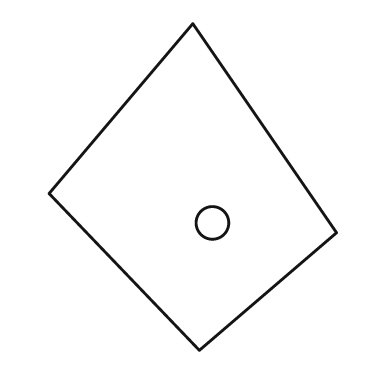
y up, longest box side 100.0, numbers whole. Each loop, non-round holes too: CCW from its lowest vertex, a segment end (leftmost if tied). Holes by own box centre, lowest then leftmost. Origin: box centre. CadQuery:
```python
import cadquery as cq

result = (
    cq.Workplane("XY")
    .moveTo(2.0, -50.0)
    .lineTo(44.0, -14.0)
    .lineTo(0.0, 50.0)
    .lineTo(-44.0, -2.0)
    .close()
    .moveTo(6.0, -11.0)
    .circle(5.0)
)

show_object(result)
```